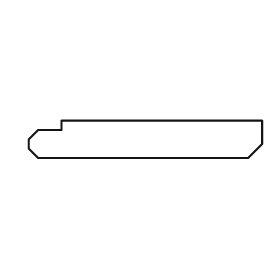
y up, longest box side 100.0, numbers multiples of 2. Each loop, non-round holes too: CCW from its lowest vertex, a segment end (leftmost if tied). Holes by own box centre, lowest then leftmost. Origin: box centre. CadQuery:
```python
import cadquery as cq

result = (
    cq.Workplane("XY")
    .moveTo(-46.0, -8.0)
    .lineTo(44.0, -8.0)
    .lineTo(50.0, -2.0)
    .lineTo(50.0, 8.0)
    .lineTo(-36.0, 8.0)
    .lineTo(-36.0, 4.0)
    .lineTo(-46.0, 4.0)
    .lineTo(-50.0, 0.0)
    .lineTo(-50.0, -4.0)
    .close()
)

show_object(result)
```